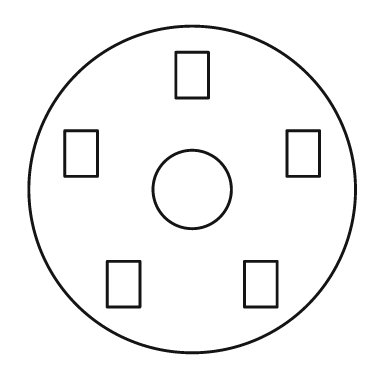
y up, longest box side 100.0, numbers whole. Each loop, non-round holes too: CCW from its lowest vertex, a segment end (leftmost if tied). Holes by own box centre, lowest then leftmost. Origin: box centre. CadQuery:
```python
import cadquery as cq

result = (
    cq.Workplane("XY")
    .moveTo(0.0, 0.0)
    .circle(50.0)
    .moveTo(-26.0, -36.0)
    .lineTo(-16.0, -36.0)
    .lineTo(-16.0, -22.0)
    .lineTo(-26.0, -22.0)
    .close()
    .moveTo(16.0, -36.0)
    .lineTo(26.0, -36.0)
    .lineTo(26.0, -22.0)
    .lineTo(16.0, -22.0)
    .close()
    .moveTo(0.0, 0.0)
    .circle(12.0)
    .moveTo(-39.0, 4.0)
    .lineTo(-29.0, 4.0)
    .lineTo(-29.0, 18.0)
    .lineTo(-39.0, 18.0)
    .close()
    .moveTo(29.0, 4.0)
    .lineTo(39.0, 4.0)
    .lineTo(39.0, 18.0)
    .lineTo(29.0, 18.0)
    .close()
    .moveTo(-5.0, 28.0)
    .lineTo(5.0, 28.0)
    .lineTo(5.0, 42.0)
    .lineTo(-5.0, 42.0)
    .close()
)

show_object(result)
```